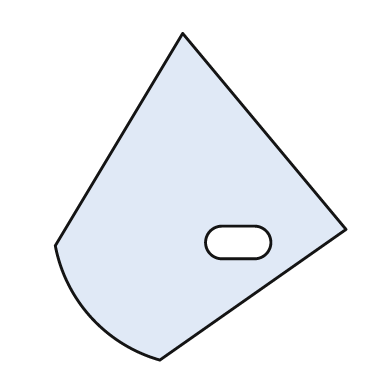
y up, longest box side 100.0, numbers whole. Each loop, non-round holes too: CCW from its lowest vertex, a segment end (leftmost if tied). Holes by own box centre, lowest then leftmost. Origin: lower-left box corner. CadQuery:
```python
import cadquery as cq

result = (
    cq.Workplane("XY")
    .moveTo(32.0, 0.0)
    .lineTo(89.0, 40.0)
    .lineTo(39.0, 100.0)
    .lineTo(0.0, 35.0)
    .threePointArc((11.0, 13.0), (32.0, 0.0))
    .close()
    .moveTo(51.0, 31.0)
    .lineTo(61.0, 31.0)
    .threePointArc((66.0, 36.0), (61.0, 41.0))
    .lineTo(51.0, 41.0)
    .threePointArc((46.0, 36.0), (51.0, 31.0))
    .close()
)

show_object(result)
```